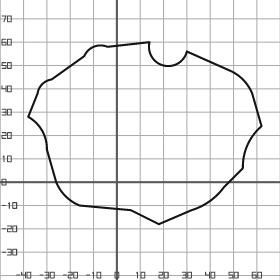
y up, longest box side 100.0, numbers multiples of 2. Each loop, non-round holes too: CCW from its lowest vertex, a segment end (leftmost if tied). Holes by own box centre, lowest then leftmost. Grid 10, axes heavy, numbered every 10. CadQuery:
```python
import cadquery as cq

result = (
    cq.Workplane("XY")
    .moveTo(18.0, -18.0)
    .lineTo(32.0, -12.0)
    .threePointArc((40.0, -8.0), (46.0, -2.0))
    .lineTo(54.0, 6.0)
    .threePointArc((56.0, 16.0), (62.0, 24.0))
    .lineTo(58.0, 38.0)
    .threePointArc((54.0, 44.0), (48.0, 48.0))
    .lineTo(30.0, 56.0)
    .threePointArc((20.0, 50.0), (14.0, 60.0))
    .lineTo(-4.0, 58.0)
    .threePointArc((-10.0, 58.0), (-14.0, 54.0))
    .lineTo(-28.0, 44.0)
    .threePointArc((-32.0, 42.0), (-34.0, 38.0))
    .lineTo(-38.0, 28.0)
    .threePointArc((-32.0, 22.0), (-30.0, 14.0))
    .lineTo(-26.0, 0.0)
    .threePointArc((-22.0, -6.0), (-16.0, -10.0))
    .lineTo(6.0, -12.0)
    .close()
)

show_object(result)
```